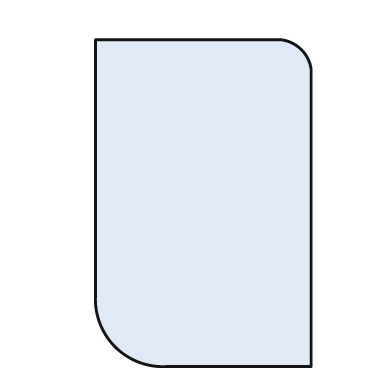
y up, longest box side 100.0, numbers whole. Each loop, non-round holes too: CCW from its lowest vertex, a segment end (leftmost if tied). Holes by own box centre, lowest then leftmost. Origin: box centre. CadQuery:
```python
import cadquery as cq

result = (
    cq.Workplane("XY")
    .moveTo(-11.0, -50.0)
    .lineTo(33.0, -50.0)
    .lineTo(33.0, 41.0)
    .threePointArc((30.0, 47.0), (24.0, 50.0))
    .lineTo(-33.0, 50.0)
    .lineTo(-33.0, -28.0)
    .threePointArc((-27.0, -44.0), (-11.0, -50.0))
    .close()
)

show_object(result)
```